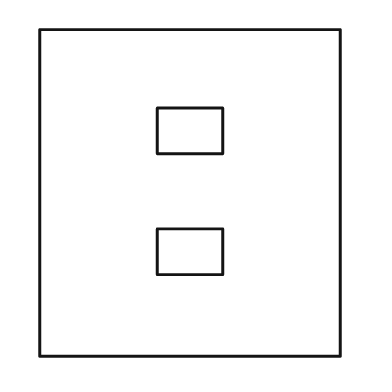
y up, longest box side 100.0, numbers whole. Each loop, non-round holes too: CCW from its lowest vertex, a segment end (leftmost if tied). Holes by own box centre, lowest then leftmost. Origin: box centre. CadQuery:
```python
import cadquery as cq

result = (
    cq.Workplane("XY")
    .moveTo(-46.0, -50.0)
    .lineTo(46.0, -50.0)
    .lineTo(46.0, 50.0)
    .lineTo(-46.0, 50.0)
    .close()
    .moveTo(-10.0, -25.0)
    .lineTo(10.0, -25.0)
    .lineTo(10.0, -11.0)
    .lineTo(-10.0, -11.0)
    .close()
    .moveTo(-10.0, 12.0)
    .lineTo(10.0, 12.0)
    .lineTo(10.0, 26.0)
    .lineTo(-10.0, 26.0)
    .close()
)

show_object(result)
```